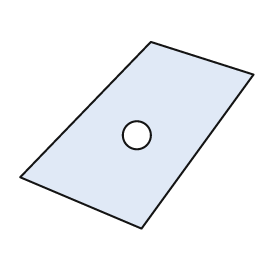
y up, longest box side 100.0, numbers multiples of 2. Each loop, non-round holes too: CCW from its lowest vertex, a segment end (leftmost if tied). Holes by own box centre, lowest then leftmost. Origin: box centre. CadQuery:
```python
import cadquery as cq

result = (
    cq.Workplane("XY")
    .moveTo(2.0, -40.0)
    .lineTo(50.0, 26.0)
    .lineTo(6.0, 40.0)
    .lineTo(-50.0, -18.0)
    .close()
    .moveTo(0.0, 0.0)
    .circle(6.0)
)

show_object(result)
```